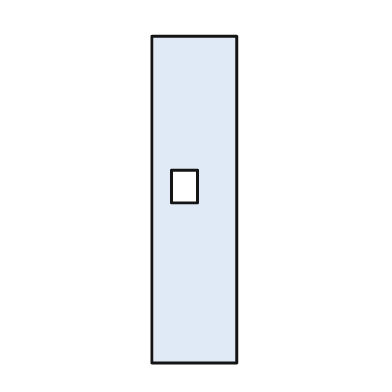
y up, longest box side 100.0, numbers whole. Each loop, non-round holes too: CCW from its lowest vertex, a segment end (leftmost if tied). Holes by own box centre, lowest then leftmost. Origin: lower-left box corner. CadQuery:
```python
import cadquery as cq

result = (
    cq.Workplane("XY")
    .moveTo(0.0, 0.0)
    .lineTo(26.0, 0.0)
    .lineTo(26.0, 100.0)
    .lineTo(0.0, 100.0)
    .close()
    .moveTo(6.0, 49.0)
    .lineTo(14.0, 49.0)
    .lineTo(14.0, 59.0)
    .lineTo(6.0, 59.0)
    .close()
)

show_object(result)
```